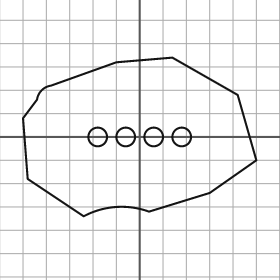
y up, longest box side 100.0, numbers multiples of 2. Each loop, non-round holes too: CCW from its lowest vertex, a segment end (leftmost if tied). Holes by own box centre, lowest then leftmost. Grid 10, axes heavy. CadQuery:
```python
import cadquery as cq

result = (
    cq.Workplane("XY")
    .moveTo(-24.0, -34.0)
    .threePointArc((-10.0, -30.0), (4.0, -32.0))
    .lineTo(30.0, -24.0)
    .lineTo(50.0, -10.0)
    .lineTo(42.0, 18.0)
    .lineTo(14.0, 34.0)
    .lineTo(-10.0, 32.0)
    .lineTo(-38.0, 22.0)
    .threePointArc((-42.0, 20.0), (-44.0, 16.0))
    .lineTo(-50.0, 8.0)
    .lineTo(-48.0, -18.0)
    .close()
    .moveTo(-18.0, 0.0)
    .circle(4.0)
    .moveTo(-6.0, 0.0)
    .circle(4.0)
    .moveTo(6.0, 0.0)
    .circle(4.0)
    .moveTo(18.0, 0.0)
    .circle(4.0)
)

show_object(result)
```